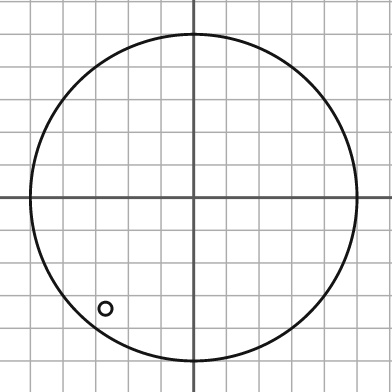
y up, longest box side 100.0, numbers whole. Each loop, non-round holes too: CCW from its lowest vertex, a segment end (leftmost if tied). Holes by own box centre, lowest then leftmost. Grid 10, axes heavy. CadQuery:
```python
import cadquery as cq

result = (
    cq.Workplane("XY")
    .moveTo(0.0, 0.0)
    .circle(50.0)
    .moveTo(-27.0, -34.0)
    .circle(2.0)
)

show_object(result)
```